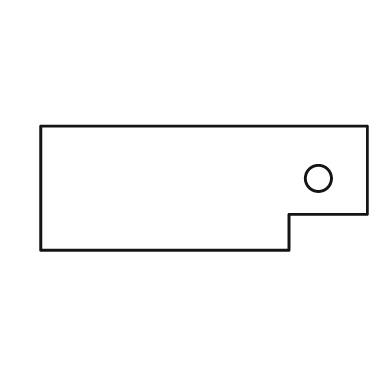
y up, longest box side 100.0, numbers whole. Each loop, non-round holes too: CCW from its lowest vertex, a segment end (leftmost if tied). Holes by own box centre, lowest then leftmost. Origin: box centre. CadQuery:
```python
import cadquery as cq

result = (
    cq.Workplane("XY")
    .moveTo(-50.0, -19.0)
    .lineTo(26.0, -19.0)
    .lineTo(26.0, -8.0)
    .lineTo(50.0, -8.0)
    .lineTo(50.0, 19.0)
    .lineTo(-50.0, 19.0)
    .close()
    .moveTo(35.0, 3.0)
    .circle(4.0)
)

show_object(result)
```